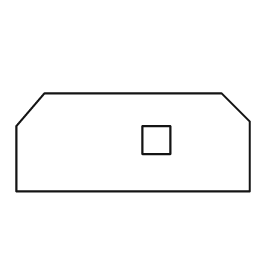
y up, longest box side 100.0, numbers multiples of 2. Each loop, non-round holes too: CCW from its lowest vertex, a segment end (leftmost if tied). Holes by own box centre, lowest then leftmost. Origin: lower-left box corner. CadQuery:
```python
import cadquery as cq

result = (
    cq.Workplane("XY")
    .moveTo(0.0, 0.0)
    .lineTo(100.0, 0.0)
    .lineTo(100.0, 30.0)
    .lineTo(88.0, 42.0)
    .lineTo(12.0, 42.0)
    .lineTo(0.0, 28.0)
    .close()
    .moveTo(54.0, 16.0)
    .lineTo(66.0, 16.0)
    .lineTo(66.0, 28.0)
    .lineTo(54.0, 28.0)
    .close()
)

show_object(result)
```